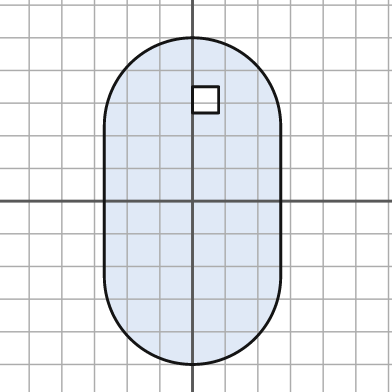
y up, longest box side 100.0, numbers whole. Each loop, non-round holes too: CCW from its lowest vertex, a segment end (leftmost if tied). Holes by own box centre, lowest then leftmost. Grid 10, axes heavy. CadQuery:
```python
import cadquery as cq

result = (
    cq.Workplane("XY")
    .moveTo(-27.0, -23.0)
    .threePointArc((0.0, -50.0), (27.0, -23.0))
    .lineTo(27.0, 23.0)
    .threePointArc((0.0, 50.0), (-27.0, 23.0))
    .close()
    .moveTo(0.0, 27.0)
    .lineTo(8.0, 27.0)
    .lineTo(8.0, 35.0)
    .lineTo(0.0, 35.0)
    .close()
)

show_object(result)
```